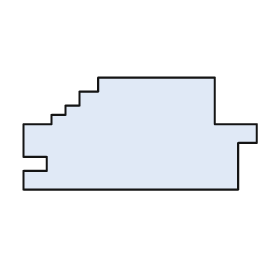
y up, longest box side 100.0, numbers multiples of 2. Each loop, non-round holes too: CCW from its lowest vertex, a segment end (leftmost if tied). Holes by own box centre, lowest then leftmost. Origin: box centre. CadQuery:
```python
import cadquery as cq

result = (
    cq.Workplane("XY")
    .moveTo(-50.0, -24.0)
    .lineTo(42.0, -24.0)
    .lineTo(42.0, -4.0)
    .lineTo(50.0, -4.0)
    .lineTo(50.0, 4.0)
    .lineTo(32.0, 4.0)
    .lineTo(32.0, 24.0)
    .lineTo(-18.0, 24.0)
    .lineTo(-18.0, 18.0)
    .lineTo(-26.0, 18.0)
    .lineTo(-26.0, 12.0)
    .lineTo(-32.0, 12.0)
    .lineTo(-32.0, 8.0)
    .lineTo(-38.0, 8.0)
    .lineTo(-38.0, 4.0)
    .lineTo(-50.0, 4.0)
    .lineTo(-50.0, -10.0)
    .lineTo(-40.0, -10.0)
    .lineTo(-40.0, -16.0)
    .lineTo(-50.0, -16.0)
    .close()
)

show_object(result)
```